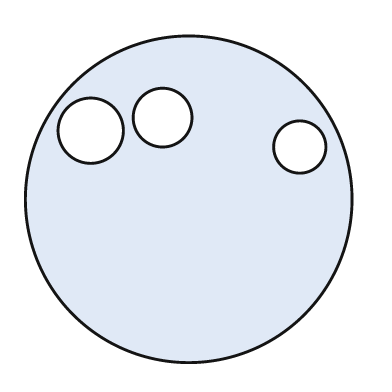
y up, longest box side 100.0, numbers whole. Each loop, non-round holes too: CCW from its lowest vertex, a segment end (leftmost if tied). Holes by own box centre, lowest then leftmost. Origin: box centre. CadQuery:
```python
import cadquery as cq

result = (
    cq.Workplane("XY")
    .moveTo(0.0, 0.0)
    .circle(50.0)
    .moveTo(34.0, 16.0)
    .circle(8.0)
    .moveTo(-30.0, 21.0)
    .circle(10.0)
    .moveTo(-8.0, 25.0)
    .circle(9.0)
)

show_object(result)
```